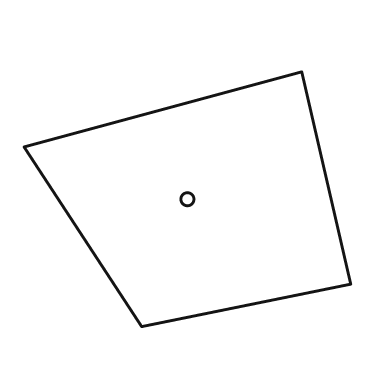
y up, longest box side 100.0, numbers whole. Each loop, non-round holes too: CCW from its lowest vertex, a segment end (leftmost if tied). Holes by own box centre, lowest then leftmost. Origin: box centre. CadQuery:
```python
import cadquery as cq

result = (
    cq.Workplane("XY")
    .moveTo(-14.0, -39.0)
    .lineTo(50.0, -26.0)
    .lineTo(35.0, 39.0)
    .lineTo(-50.0, 16.0)
    .close()
    .moveTo(0.0, 0.0)
    .circle(2.0)
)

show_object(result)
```